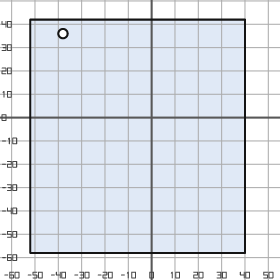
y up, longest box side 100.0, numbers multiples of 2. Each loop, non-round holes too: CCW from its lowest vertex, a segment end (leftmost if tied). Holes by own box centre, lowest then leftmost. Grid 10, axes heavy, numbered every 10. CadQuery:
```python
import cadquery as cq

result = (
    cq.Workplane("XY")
    .moveTo(-52.0, -58.0)
    .lineTo(40.0, -58.0)
    .lineTo(40.0, 42.0)
    .lineTo(-52.0, 42.0)
    .close()
    .moveTo(-38.0, 36.0)
    .circle(2.0)
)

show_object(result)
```